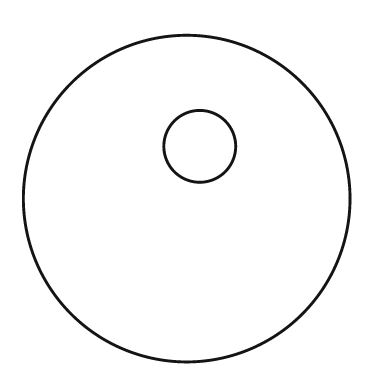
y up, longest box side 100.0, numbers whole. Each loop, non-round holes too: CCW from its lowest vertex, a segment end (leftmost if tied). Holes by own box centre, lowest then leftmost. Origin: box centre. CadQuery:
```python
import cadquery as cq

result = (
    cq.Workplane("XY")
    .moveTo(0.0, 0.0)
    .circle(50.0)
    .moveTo(4.0, 16.0)
    .circle(11.0)
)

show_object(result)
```